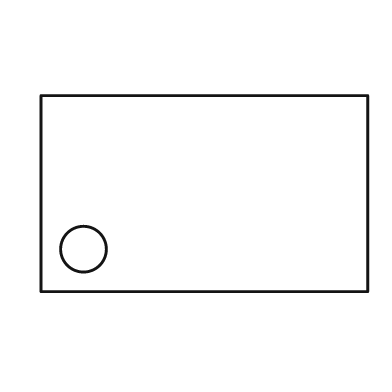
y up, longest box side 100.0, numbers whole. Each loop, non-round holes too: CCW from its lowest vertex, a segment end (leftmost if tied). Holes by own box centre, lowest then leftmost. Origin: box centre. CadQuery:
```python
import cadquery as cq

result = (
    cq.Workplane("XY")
    .moveTo(-50.0, -30.0)
    .lineTo(50.0, -30.0)
    .lineTo(50.0, 30.0)
    .lineTo(-50.0, 30.0)
    .close()
    .moveTo(-37.0, -17.0)
    .circle(7.0)
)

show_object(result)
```